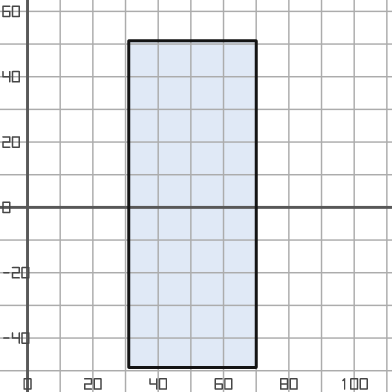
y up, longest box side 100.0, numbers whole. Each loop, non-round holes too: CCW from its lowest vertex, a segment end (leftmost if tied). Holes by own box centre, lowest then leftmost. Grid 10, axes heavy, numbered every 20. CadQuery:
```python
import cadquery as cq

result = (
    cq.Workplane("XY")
    .moveTo(31.0, -49.0)
    .lineTo(70.0, -49.0)
    .lineTo(70.0, 51.0)
    .lineTo(31.0, 51.0)
    .close()
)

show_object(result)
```